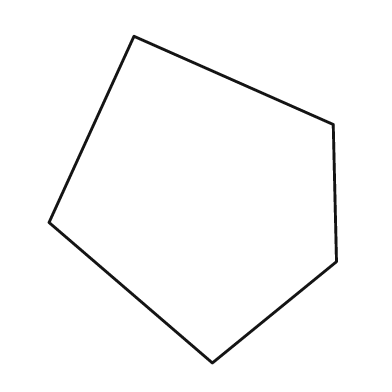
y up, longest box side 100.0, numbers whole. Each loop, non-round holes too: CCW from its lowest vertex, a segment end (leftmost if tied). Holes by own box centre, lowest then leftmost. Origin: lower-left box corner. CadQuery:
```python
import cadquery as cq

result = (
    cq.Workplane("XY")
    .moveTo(50.0, 0.0)
    .lineTo(88.0, 31.0)
    .lineTo(87.0, 73.0)
    .lineTo(26.0, 100.0)
    .lineTo(0.0, 43.0)
    .close()
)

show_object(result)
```